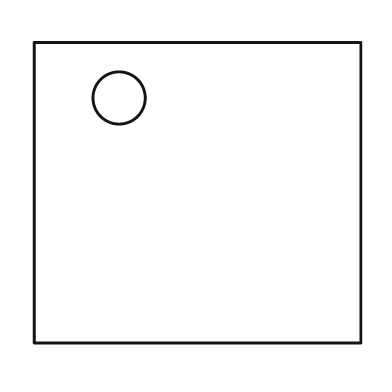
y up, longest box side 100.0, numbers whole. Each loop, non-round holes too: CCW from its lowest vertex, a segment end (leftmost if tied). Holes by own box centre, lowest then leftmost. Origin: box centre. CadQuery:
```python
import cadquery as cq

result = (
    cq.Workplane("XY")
    .moveTo(-50.0, -46.0)
    .lineTo(50.0, -46.0)
    .lineTo(50.0, 46.0)
    .lineTo(-50.0, 46.0)
    .close()
    .moveTo(-24.0, 29.0)
    .circle(8.0)
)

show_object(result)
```